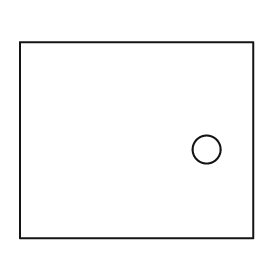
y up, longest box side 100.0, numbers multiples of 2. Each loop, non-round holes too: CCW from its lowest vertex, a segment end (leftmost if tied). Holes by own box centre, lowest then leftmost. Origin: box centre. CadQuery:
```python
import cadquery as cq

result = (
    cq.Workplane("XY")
    .moveTo(-50.0, -42.0)
    .lineTo(50.0, -42.0)
    .lineTo(50.0, 42.0)
    .lineTo(-50.0, 42.0)
    .close()
    .moveTo(30.0, -4.0)
    .circle(6.0)
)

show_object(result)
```